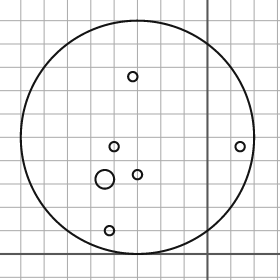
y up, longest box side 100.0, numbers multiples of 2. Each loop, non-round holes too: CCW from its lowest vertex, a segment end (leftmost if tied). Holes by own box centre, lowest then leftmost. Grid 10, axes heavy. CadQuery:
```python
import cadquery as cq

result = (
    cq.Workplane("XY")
    .moveTo(-30.0, 50.0)
    .circle(50.0)
    .moveTo(-42.0, 10.0)
    .circle(2.0)
    .moveTo(-44.0, 32.0)
    .circle(4.0)
    .moveTo(-30.0, 34.0)
    .circle(2.0)
    .moveTo(-40.0, 46.0)
    .circle(2.0)
    .moveTo(14.0, 46.0)
    .circle(2.0)
    .moveTo(-32.0, 76.0)
    .circle(2.0)
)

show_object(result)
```